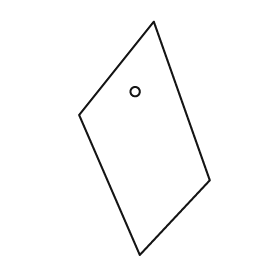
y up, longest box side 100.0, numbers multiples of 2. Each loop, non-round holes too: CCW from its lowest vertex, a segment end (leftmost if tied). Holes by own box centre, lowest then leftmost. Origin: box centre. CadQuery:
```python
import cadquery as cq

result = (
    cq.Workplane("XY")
    .moveTo(-2.0, -50.0)
    .lineTo(28.0, -18.0)
    .lineTo(4.0, 50.0)
    .lineTo(-28.0, 10.0)
    .close()
    .moveTo(-4.0, 20.0)
    .circle(2.0)
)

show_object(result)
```